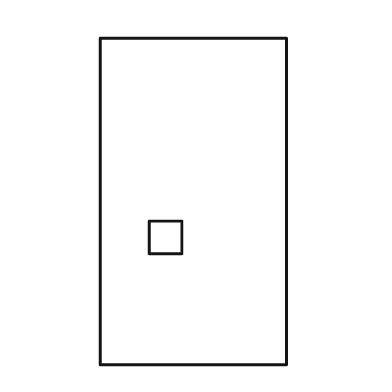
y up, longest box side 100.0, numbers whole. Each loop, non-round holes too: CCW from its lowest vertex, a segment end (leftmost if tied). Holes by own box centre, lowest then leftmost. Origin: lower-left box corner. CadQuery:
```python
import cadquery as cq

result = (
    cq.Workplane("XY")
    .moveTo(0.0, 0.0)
    .lineTo(57.0, 0.0)
    .lineTo(57.0, 100.0)
    .lineTo(0.0, 100.0)
    .close()
    .moveTo(15.0, 34.0)
    .lineTo(25.0, 34.0)
    .lineTo(25.0, 44.0)
    .lineTo(15.0, 44.0)
    .close()
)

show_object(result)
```